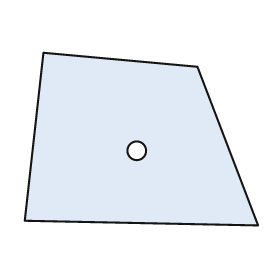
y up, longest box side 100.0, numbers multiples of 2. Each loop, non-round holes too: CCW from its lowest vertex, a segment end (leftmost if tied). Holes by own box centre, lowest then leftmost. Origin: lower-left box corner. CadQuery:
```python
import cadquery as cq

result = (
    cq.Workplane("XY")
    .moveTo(100.0, 0.0)
    .lineTo(74.0, 68.0)
    .lineTo(8.0, 74.0)
    .lineTo(0.0, 2.0)
    .close()
    .moveTo(48.0, 32.0)
    .circle(4.0)
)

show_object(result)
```